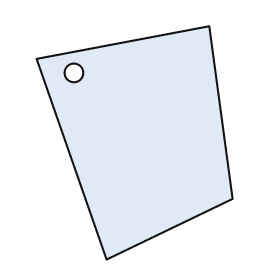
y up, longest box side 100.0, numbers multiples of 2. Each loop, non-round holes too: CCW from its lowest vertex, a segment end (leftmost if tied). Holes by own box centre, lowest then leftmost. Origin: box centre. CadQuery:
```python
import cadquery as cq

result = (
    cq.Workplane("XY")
    .moveTo(-12.0, -50.0)
    .lineTo(42.0, -24.0)
    .lineTo(32.0, 50.0)
    .lineTo(-42.0, 36.0)
    .close()
    .moveTo(-26.0, 30.0)
    .circle(4.0)
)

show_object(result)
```